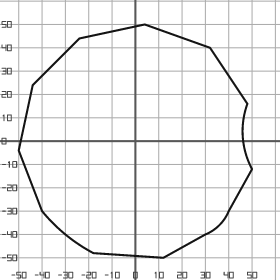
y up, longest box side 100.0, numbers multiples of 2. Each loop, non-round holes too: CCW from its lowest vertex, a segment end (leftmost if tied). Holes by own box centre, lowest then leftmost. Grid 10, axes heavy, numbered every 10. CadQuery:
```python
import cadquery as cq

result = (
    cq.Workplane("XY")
    .moveTo(12.0, -50.0)
    .lineTo(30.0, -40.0)
    .threePointArc((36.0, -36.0), (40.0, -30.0))
    .lineTo(50.0, -12.0)
    .threePointArc((46.0, 2.0), (48.0, 16.0))
    .lineTo(32.0, 40.0)
    .lineTo(4.0, 50.0)
    .lineTo(-24.0, 44.0)
    .lineTo(-44.0, 24.0)
    .lineTo(-50.0, -4.0)
    .lineTo(-40.0, -30.0)
    .threePointArc((-30.0, -40.0), (-18.0, -48.0))
    .close()
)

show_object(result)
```